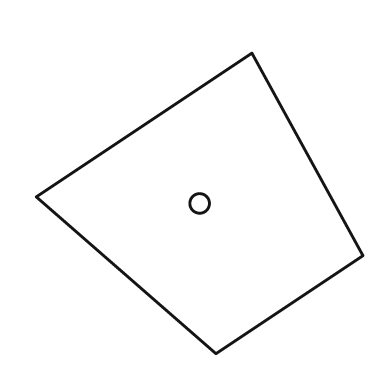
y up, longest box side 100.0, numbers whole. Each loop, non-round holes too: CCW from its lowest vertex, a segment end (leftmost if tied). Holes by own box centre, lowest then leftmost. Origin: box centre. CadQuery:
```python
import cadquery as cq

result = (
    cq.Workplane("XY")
    .moveTo(5.0, -46.0)
    .lineTo(50.0, -16.0)
    .lineTo(16.0, 46.0)
    .lineTo(-50.0, 2.0)
    .close()
    .moveTo(0.0, 0.0)
    .circle(3.0)
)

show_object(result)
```